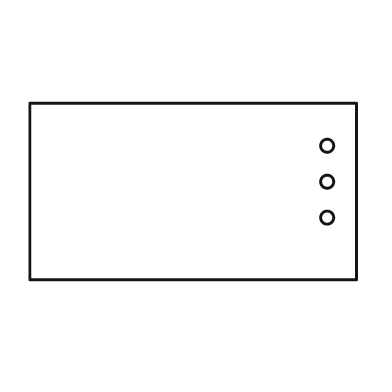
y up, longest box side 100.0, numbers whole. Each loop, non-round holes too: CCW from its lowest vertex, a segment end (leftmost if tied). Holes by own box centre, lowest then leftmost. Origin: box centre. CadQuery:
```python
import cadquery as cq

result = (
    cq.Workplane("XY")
    .moveTo(-50.0, -27.0)
    .lineTo(50.0, -27.0)
    .lineTo(50.0, 27.0)
    .lineTo(-50.0, 27.0)
    .close()
    .moveTo(41.0, -8.0)
    .circle(2.0)
    .moveTo(41.0, 3.0)
    .circle(2.0)
    .moveTo(41.0, 14.0)
    .circle(2.0)
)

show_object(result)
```